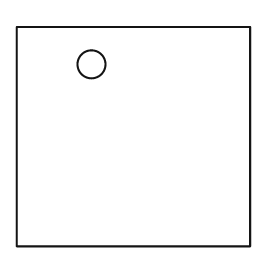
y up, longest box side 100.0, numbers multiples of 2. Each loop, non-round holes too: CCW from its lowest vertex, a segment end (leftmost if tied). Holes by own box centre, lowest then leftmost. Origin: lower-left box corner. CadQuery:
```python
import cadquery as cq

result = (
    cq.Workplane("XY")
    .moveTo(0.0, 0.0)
    .lineTo(100.0, 0.0)
    .lineTo(100.0, 94.0)
    .lineTo(0.0, 94.0)
    .close()
    .moveTo(32.0, 78.0)
    .circle(6.0)
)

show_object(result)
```